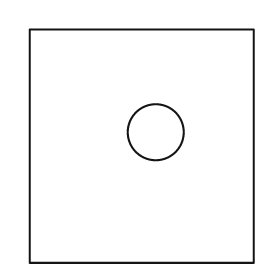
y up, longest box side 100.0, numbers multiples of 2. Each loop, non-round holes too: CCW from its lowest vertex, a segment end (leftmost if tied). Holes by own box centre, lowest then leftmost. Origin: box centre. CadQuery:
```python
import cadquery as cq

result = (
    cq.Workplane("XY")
    .moveTo(-48.0, -50.0)
    .lineTo(48.0, -50.0)
    .lineTo(48.0, 50.0)
    .lineTo(-48.0, 50.0)
    .close()
    .moveTo(6.0, 6.0)
    .circle(12.0)
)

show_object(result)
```